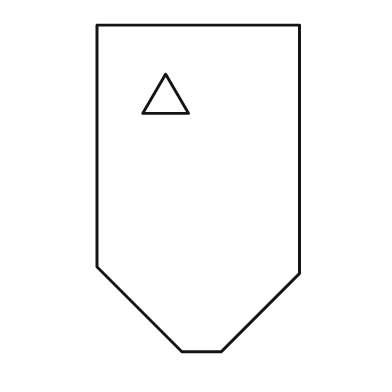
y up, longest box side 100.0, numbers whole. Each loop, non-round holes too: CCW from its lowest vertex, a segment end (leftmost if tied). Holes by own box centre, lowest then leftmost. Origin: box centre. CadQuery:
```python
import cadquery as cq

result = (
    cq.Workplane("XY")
    .moveTo(-5.0, -50.0)
    .lineTo(7.0, -50.0)
    .lineTo(31.0, -26.0)
    .lineTo(31.0, 50.0)
    .lineTo(-31.0, 50.0)
    .lineTo(-31.0, -24.0)
    .close()
    .moveTo(-17.0, 23.0)
    .lineTo(-3.0, 23.0)
    .lineTo(-10.0, 35.0)
    .close()
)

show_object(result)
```